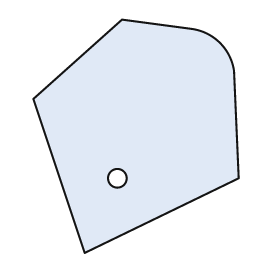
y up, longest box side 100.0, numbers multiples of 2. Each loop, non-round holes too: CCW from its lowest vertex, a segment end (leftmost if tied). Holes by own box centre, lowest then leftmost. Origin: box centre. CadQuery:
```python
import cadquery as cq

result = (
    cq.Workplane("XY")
    .moveTo(-22.0, -50.0)
    .lineTo(44.0, -18.0)
    .lineTo(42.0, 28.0)
    .threePointArc((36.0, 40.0), (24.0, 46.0))
    .lineTo(-6.0, 50.0)
    .lineTo(-44.0, 16.0)
    .close()
    .moveTo(-8.0, -18.0)
    .circle(4.0)
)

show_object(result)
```